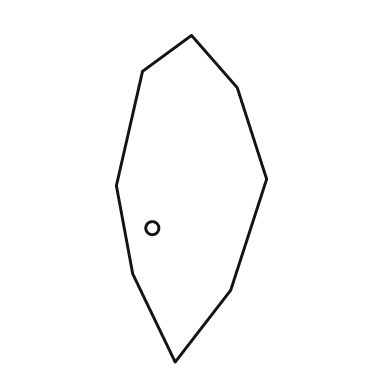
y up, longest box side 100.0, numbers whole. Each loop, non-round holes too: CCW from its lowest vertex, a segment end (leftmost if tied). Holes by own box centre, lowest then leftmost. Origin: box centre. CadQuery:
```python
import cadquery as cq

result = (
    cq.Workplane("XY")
    .moveTo(-5.0, -50.0)
    .lineTo(12.0, -28.0)
    .lineTo(23.0, 6.0)
    .lineTo(14.0, 34.0)
    .lineTo(0.0, 50.0)
    .lineTo(-15.0, 39.0)
    .lineTo(-23.0, 4.0)
    .lineTo(-18.0, -23.0)
    .close()
    .moveTo(-12.0, -9.0)
    .circle(2.0)
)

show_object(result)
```